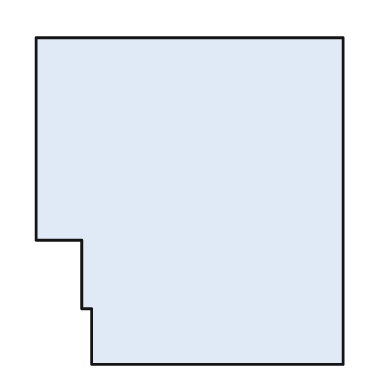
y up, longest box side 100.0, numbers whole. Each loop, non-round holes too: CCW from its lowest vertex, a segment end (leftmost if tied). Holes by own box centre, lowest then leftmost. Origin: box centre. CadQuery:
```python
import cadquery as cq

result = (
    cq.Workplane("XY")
    .moveTo(-30.0, -50.0)
    .lineTo(47.0, -50.0)
    .lineTo(47.0, 50.0)
    .lineTo(-47.0, 50.0)
    .lineTo(-47.0, -12.0)
    .lineTo(-33.0, -12.0)
    .lineTo(-33.0, -33.0)
    .lineTo(-30.0, -33.0)
    .close()
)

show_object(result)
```